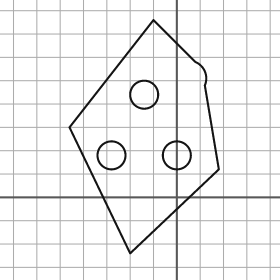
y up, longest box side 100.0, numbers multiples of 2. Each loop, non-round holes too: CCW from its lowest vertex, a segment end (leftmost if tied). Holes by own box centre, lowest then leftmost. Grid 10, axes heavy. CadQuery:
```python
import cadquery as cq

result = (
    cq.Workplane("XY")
    .moveTo(-20.0, -24.0)
    .lineTo(18.0, 12.0)
    .lineTo(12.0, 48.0)
    .threePointArc((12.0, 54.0), (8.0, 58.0))
    .lineTo(-10.0, 76.0)
    .lineTo(-46.0, 30.0)
    .close()
    .moveTo(-28.0, 18.0)
    .circle(6.0)
    .moveTo(0.0, 18.0)
    .circle(6.0)
    .moveTo(-14.0, 44.0)
    .circle(6.0)
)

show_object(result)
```